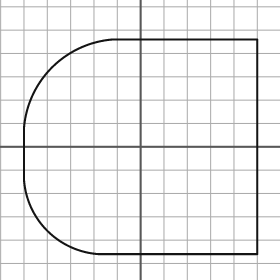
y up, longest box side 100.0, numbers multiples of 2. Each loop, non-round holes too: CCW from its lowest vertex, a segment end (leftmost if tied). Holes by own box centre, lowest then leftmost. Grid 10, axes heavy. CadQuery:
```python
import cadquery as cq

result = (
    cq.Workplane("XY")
    .moveTo(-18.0, -46.0)
    .lineTo(50.0, -46.0)
    .lineTo(50.0, 46.0)
    .lineTo(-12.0, 46.0)
    .threePointArc((-38.0, 34.0), (-50.0, 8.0))
    .lineTo(-50.0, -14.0)
    .threePointArc((-40.0, -36.0), (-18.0, -46.0))
    .close()
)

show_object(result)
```